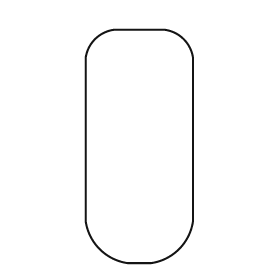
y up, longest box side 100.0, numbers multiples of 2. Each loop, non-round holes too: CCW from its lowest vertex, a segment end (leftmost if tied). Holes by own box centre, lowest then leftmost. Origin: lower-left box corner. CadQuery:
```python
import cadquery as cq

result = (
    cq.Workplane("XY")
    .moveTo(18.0, 0.0)
    .lineTo(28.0, 0.0)
    .threePointArc((40.0, 6.0), (46.0, 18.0))
    .lineTo(46.0, 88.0)
    .threePointArc((42.0, 96.0), (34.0, 100.0))
    .lineTo(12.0, 100.0)
    .threePointArc((4.0, 96.0), (0.0, 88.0))
    .lineTo(0.0, 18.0)
    .threePointArc((6.0, 6.0), (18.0, 0.0))
    .close()
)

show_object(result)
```